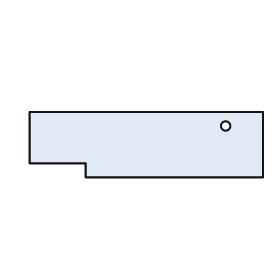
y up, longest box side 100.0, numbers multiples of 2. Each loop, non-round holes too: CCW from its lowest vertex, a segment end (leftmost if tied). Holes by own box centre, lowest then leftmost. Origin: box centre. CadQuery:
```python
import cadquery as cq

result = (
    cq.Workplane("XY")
    .moveTo(-26.0, -14.0)
    .lineTo(50.0, -14.0)
    .lineTo(50.0, 14.0)
    .lineTo(-50.0, 14.0)
    .lineTo(-50.0, -8.0)
    .lineTo(-26.0, -8.0)
    .close()
    .moveTo(34.0, 8.0)
    .circle(2.0)
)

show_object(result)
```